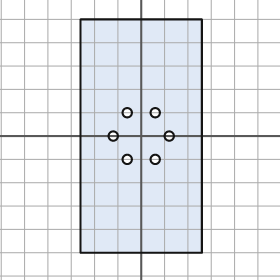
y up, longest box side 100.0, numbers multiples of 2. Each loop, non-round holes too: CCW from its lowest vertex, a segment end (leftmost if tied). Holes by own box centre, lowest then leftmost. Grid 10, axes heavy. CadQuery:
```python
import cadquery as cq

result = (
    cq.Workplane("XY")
    .moveTo(-26.0, -50.0)
    .lineTo(26.0, -50.0)
    .lineTo(26.0, 50.0)
    .lineTo(-26.0, 50.0)
    .close()
    .moveTo(-6.0, -10.0)
    .circle(2.0)
    .moveTo(6.0, -10.0)
    .circle(2.0)
    .moveTo(-12.0, 0.0)
    .circle(2.0)
    .moveTo(12.0, 0.0)
    .circle(2.0)
    .moveTo(-6.0, 10.0)
    .circle(2.0)
    .moveTo(6.0, 10.0)
    .circle(2.0)
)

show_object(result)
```